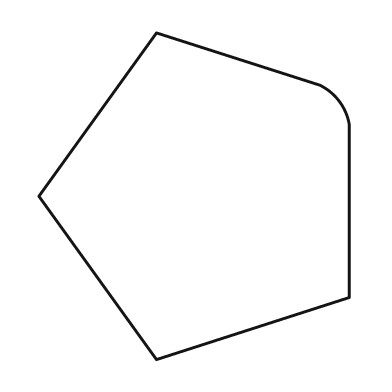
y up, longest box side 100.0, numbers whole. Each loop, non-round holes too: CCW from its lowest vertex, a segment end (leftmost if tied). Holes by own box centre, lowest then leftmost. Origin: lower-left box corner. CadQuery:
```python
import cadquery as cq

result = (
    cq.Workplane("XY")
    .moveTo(36.0, 0.0)
    .lineTo(95.0, 19.0)
    .lineTo(95.0, 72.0)
    .threePointArc((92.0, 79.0), (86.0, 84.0))
    .lineTo(36.0, 100.0)
    .lineTo(0.0, 50.0)
    .close()
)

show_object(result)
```